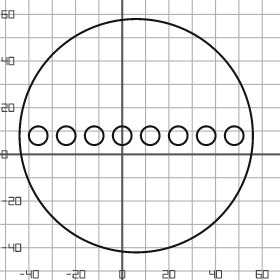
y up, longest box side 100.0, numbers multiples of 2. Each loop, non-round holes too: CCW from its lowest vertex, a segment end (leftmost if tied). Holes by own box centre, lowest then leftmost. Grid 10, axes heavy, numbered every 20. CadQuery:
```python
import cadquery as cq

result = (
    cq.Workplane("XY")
    .moveTo(6.0, 8.0)
    .circle(50.0)
    .moveTo(-36.0, 8.0)
    .circle(4.0)
    .moveTo(-24.0, 8.0)
    .circle(4.0)
    .moveTo(-12.0, 8.0)
    .circle(4.0)
    .moveTo(0.0, 8.0)
    .circle(4.0)
    .moveTo(12.0, 8.0)
    .circle(4.0)
    .moveTo(24.0, 8.0)
    .circle(4.0)
    .moveTo(36.0, 8.0)
    .circle(4.0)
    .moveTo(48.0, 8.0)
    .circle(4.0)
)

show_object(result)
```